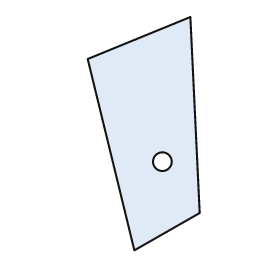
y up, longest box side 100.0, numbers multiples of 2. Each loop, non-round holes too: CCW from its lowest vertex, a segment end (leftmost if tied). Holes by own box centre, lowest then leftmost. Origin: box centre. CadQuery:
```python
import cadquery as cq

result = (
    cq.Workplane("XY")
    .moveTo(-4.0, -50.0)
    .lineTo(24.0, -34.0)
    .lineTo(20.0, 50.0)
    .lineTo(-24.0, 32.0)
    .close()
    .moveTo(8.0, -12.0)
    .circle(4.0)
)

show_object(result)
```